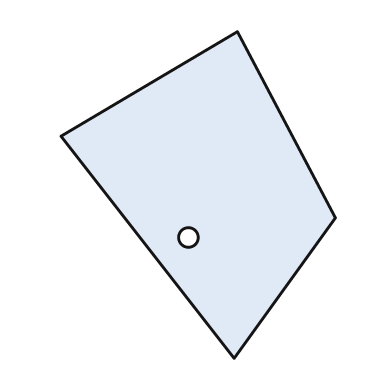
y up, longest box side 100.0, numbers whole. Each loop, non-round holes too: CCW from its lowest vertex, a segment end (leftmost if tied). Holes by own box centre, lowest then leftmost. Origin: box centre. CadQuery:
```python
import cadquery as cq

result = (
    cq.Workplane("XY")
    .moveTo(11.0, -50.0)
    .lineTo(42.0, -7.0)
    .lineTo(12.0, 50.0)
    .lineTo(-42.0, 18.0)
    .close()
    .moveTo(-3.0, -13.0)
    .circle(3.0)
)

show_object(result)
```